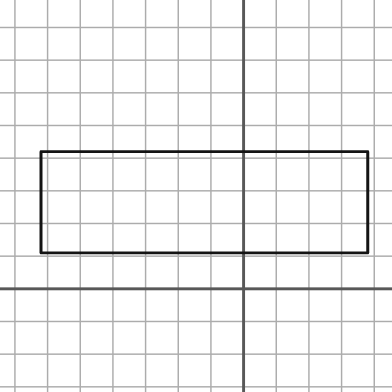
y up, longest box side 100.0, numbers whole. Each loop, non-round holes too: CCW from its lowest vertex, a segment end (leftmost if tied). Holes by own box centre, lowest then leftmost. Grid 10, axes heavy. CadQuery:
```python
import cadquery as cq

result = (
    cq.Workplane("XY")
    .moveTo(-62.0, 11.0)
    .lineTo(38.0, 11.0)
    .lineTo(38.0, 42.0)
    .lineTo(-62.0, 42.0)
    .close()
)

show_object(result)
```